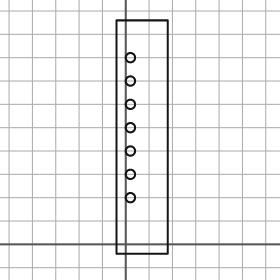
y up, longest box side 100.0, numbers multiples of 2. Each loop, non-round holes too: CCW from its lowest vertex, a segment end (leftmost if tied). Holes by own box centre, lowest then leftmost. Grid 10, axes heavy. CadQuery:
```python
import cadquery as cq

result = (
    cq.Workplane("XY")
    .moveTo(-4.0, -4.0)
    .lineTo(18.0, -4.0)
    .lineTo(18.0, 96.0)
    .lineTo(-4.0, 96.0)
    .close()
    .moveTo(2.0, 20.0)
    .circle(2.0)
    .moveTo(2.0, 30.0)
    .circle(2.0)
    .moveTo(2.0, 40.0)
    .circle(2.0)
    .moveTo(2.0, 50.0)
    .circle(2.0)
    .moveTo(2.0, 60.0)
    .circle(2.0)
    .moveTo(2.0, 70.0)
    .circle(2.0)
    .moveTo(2.0, 80.0)
    .circle(2.0)
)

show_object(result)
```